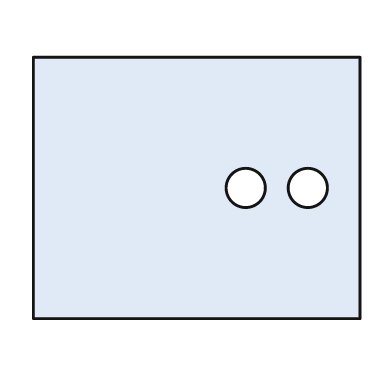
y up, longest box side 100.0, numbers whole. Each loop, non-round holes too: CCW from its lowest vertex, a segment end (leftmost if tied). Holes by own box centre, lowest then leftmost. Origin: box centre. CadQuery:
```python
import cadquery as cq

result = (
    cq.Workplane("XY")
    .moveTo(-50.0, -40.0)
    .lineTo(50.0, -40.0)
    .lineTo(50.0, 40.0)
    .lineTo(-50.0, 40.0)
    .close()
    .moveTo(15.0, 0.0)
    .circle(6.0)
    .moveTo(34.0, 0.0)
    .circle(6.0)
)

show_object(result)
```